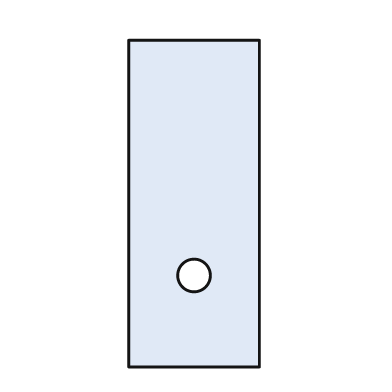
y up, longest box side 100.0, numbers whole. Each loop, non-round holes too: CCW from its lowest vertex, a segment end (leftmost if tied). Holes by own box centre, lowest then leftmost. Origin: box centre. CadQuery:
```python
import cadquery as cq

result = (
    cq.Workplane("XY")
    .moveTo(-20.0, -50.0)
    .lineTo(20.0, -50.0)
    .lineTo(20.0, 50.0)
    .lineTo(-20.0, 50.0)
    .close()
    .moveTo(0.0, -22.0)
    .circle(5.0)
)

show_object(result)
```